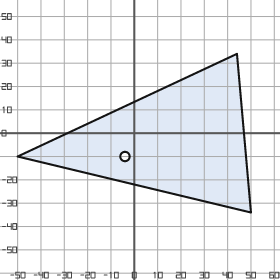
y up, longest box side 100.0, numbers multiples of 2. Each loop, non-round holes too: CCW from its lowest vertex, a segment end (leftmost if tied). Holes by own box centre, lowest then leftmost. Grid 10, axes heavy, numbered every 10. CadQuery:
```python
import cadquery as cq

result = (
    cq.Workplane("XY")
    .moveTo(50.0, -34.0)
    .lineTo(44.0, 34.0)
    .lineTo(-50.0, -10.0)
    .close()
    .moveTo(-4.0, -10.0)
    .circle(2.0)
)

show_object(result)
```